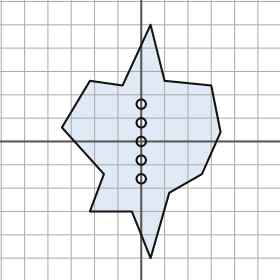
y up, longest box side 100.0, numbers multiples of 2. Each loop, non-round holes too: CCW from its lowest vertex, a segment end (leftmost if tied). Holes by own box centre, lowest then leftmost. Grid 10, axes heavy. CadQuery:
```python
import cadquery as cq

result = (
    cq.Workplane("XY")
    .moveTo(4.0, -50.0)
    .lineTo(12.0, -22.0)
    .lineTo(26.0, -14.0)
    .lineTo(34.0, 4.0)
    .lineTo(30.0, 24.0)
    .lineTo(10.0, 26.0)
    .lineTo(4.0, 50.0)
    .lineTo(-8.0, 24.0)
    .lineTo(-22.0, 26.0)
    .lineTo(-34.0, 6.0)
    .lineTo(-16.0, -14.0)
    .lineTo(-22.0, -30.0)
    .lineTo(-4.0, -30.0)
    .close()
    .moveTo(0.0, -16.0)
    .circle(2.0)
    .moveTo(0.0, -8.0)
    .circle(2.0)
    .moveTo(0.0, 0.0)
    .circle(2.0)
    .moveTo(0.0, 8.0)
    .circle(2.0)
    .moveTo(0.0, 16.0)
    .circle(2.0)
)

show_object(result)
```